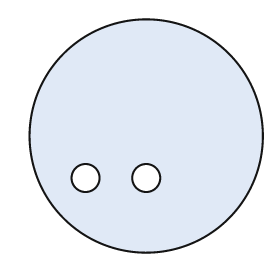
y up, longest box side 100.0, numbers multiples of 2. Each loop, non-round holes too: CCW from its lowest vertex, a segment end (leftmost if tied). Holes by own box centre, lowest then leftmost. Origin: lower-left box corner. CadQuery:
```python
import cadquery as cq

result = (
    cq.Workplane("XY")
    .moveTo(50.0, 50.0)
    .circle(50.0)
    .moveTo(24.0, 32.0)
    .circle(6.0)
    .moveTo(50.0, 32.0)
    .circle(6.0)
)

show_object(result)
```